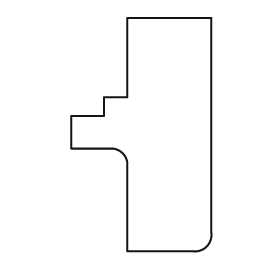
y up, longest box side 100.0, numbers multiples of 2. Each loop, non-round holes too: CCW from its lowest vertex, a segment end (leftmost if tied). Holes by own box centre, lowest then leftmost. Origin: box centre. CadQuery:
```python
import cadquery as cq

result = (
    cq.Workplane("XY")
    .moveTo(-6.0, -50.0)
    .lineTo(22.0, -50.0)
    .threePointArc((28.0, -48.0), (30.0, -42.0))
    .lineTo(30.0, 50.0)
    .lineTo(-6.0, 50.0)
    .lineTo(-6.0, 16.0)
    .lineTo(-16.0, 16.0)
    .lineTo(-16.0, 8.0)
    .lineTo(-30.0, 8.0)
    .lineTo(-30.0, -6.0)
    .lineTo(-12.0, -6.0)
    .threePointArc((-8.0, -8.0), (-6.0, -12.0))
    .close()
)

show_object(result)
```